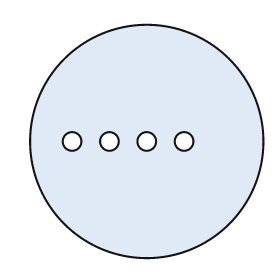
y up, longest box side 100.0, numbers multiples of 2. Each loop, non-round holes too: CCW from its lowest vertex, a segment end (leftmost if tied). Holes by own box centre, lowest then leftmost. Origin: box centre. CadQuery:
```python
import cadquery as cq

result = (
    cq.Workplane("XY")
    .moveTo(0.0, 0.0)
    .circle(50.0)
    .moveTo(-32.0, 0.0)
    .circle(4.0)
    .moveTo(-16.0, 0.0)
    .circle(4.0)
    .moveTo(0.0, 0.0)
    .circle(4.0)
    .moveTo(16.0, 0.0)
    .circle(4.0)
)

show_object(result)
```